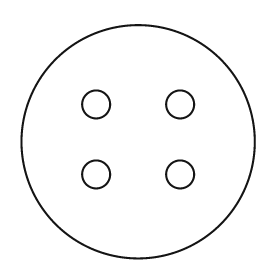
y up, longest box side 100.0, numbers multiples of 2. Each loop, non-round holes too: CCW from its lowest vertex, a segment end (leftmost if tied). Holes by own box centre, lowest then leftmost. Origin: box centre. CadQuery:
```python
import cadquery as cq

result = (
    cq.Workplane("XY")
    .moveTo(0.0, 0.0)
    .circle(50.0)
    .moveTo(-18.0, -14.0)
    .circle(6.0)
    .moveTo(18.0, -14.0)
    .circle(6.0)
    .moveTo(-18.0, 16.0)
    .circle(6.0)
    .moveTo(18.0, 16.0)
    .circle(6.0)
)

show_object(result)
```